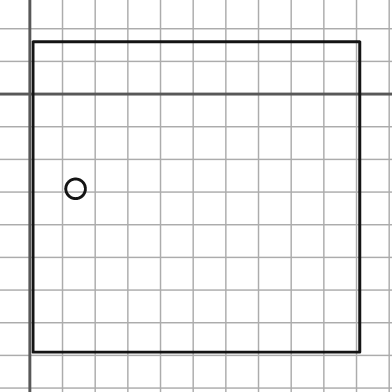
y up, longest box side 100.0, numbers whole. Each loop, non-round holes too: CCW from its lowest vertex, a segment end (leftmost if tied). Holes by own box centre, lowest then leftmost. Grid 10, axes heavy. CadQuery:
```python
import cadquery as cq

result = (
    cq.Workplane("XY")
    .moveTo(1.0, -79.0)
    .lineTo(101.0, -79.0)
    .lineTo(101.0, 16.0)
    .lineTo(1.0, 16.0)
    .close()
    .moveTo(14.0, -29.0)
    .circle(3.0)
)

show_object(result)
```